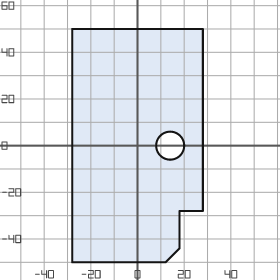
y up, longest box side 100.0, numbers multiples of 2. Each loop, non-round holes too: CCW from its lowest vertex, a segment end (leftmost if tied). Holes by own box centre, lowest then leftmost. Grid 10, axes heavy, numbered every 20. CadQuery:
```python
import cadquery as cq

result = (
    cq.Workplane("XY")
    .moveTo(-28.0, -50.0)
    .lineTo(12.0, -50.0)
    .lineTo(18.0, -44.0)
    .lineTo(18.0, -28.0)
    .lineTo(28.0, -28.0)
    .lineTo(28.0, 50.0)
    .lineTo(-28.0, 50.0)
    .close()
    .moveTo(14.0, 0.0)
    .circle(6.0)
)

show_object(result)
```